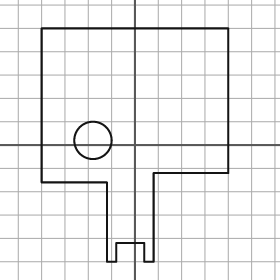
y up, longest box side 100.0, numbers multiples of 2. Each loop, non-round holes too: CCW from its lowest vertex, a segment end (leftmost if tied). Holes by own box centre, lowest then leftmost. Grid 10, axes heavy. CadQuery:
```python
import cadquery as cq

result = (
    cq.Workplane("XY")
    .moveTo(-12.0, -50.0)
    .lineTo(-8.0, -50.0)
    .lineTo(-8.0, -42.0)
    .lineTo(4.0, -42.0)
    .lineTo(4.0, -50.0)
    .lineTo(8.0, -50.0)
    .lineTo(8.0, -12.0)
    .lineTo(40.0, -12.0)
    .lineTo(40.0, 50.0)
    .lineTo(-40.0, 50.0)
    .lineTo(-40.0, -16.0)
    .lineTo(-12.0, -16.0)
    .close()
    .moveTo(-18.0, 2.0)
    .circle(8.0)
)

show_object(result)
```